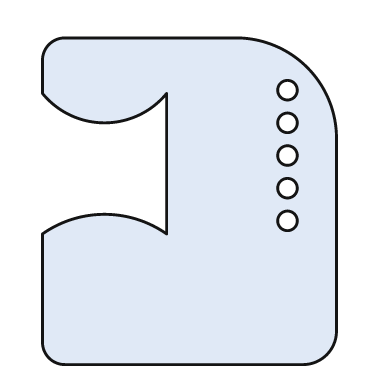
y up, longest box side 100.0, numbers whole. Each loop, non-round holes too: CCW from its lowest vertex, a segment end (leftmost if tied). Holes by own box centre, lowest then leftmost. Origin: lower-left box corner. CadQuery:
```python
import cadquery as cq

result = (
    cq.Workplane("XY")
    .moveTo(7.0, 0.0)
    .lineTo(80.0, 0.0)
    .threePointArc((87.0, 3.0), (90.0, 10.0))
    .lineTo(90.0, 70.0)
    .threePointArc((81.0, 91.0), (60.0, 100.0))
    .lineTo(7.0, 100.0)
    .threePointArc((2.0, 98.0), (0.0, 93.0))
    .lineTo(0.0, 83.0)
    .threePointArc((19.0, 74.0), (38.0, 83.0))
    .lineTo(38.0, 40.0)
    .threePointArc((19.0, 46.0), (0.0, 40.0))
    .lineTo(0.0, 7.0)
    .threePointArc((2.0, 2.0), (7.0, 0.0))
    .close()
    .moveTo(75.0, 44.0)
    .circle(3.0)
    .moveTo(75.0, 54.0)
    .circle(3.0)
    .moveTo(75.0, 64.0)
    .circle(3.0)
    .moveTo(75.0, 74.0)
    .circle(3.0)
    .moveTo(75.0, 84.0)
    .circle(3.0)
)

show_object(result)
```